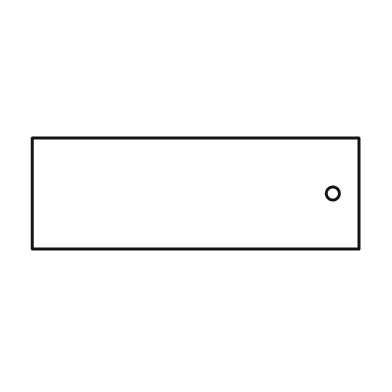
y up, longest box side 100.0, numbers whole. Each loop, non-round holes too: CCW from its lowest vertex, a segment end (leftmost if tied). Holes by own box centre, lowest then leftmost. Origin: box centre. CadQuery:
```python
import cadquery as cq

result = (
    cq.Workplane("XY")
    .moveTo(-50.0, -17.0)
    .lineTo(50.0, -17.0)
    .lineTo(50.0, 17.0)
    .lineTo(-50.0, 17.0)
    .close()
    .moveTo(42.0, 0.0)
    .circle(2.0)
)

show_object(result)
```